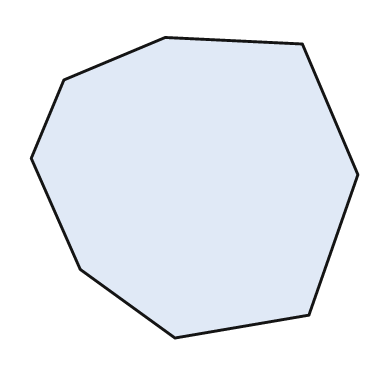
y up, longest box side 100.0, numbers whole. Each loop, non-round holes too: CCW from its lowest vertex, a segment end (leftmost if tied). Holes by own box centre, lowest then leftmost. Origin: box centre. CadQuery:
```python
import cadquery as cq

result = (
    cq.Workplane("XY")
    .moveTo(-6.0, -46.0)
    .lineTo(35.0, -39.0)
    .lineTo(50.0, 4.0)
    .lineTo(33.0, 44.0)
    .lineTo(-9.0, 46.0)
    .lineTo(-40.0, 33.0)
    .lineTo(-50.0, 9.0)
    .lineTo(-35.0, -25.0)
    .close()
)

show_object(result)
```